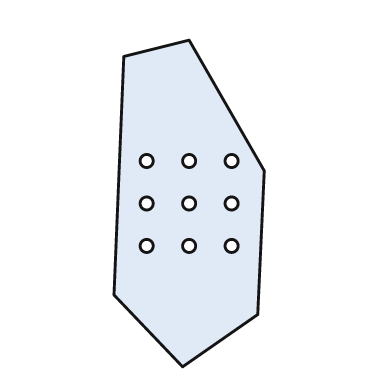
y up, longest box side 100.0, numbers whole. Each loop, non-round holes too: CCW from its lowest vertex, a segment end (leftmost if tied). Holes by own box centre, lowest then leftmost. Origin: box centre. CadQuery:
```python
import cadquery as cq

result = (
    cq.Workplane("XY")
    .moveTo(-2.0, -50.0)
    .lineTo(21.0, -34.0)
    .lineTo(23.0, 10.0)
    .lineTo(0.0, 50.0)
    .lineTo(-20.0, 45.0)
    .lineTo(-23.0, -28.0)
    .close()
    .moveTo(-13.0, -13.0)
    .circle(2.0)
    .moveTo(0.0, -13.0)
    .circle(2.0)
    .moveTo(13.0, -13.0)
    .circle(2.0)
    .moveTo(-13.0, 0.0)
    .circle(2.0)
    .moveTo(0.0, 0.0)
    .circle(2.0)
    .moveTo(13.0, 0.0)
    .circle(2.0)
    .moveTo(-13.0, 13.0)
    .circle(2.0)
    .moveTo(0.0, 13.0)
    .circle(2.0)
    .moveTo(13.0, 13.0)
    .circle(2.0)
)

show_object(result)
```